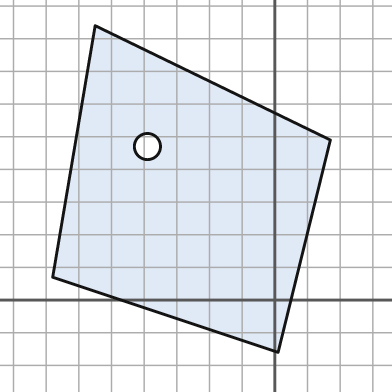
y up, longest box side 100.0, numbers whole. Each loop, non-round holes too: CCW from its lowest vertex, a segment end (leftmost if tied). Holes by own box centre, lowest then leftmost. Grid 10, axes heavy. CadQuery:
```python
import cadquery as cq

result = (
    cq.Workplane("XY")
    .moveTo(1.0, -16.0)
    .lineTo(17.0, 49.0)
    .lineTo(-55.0, 84.0)
    .lineTo(-68.0, 7.0)
    .close()
    .moveTo(-39.0, 47.0)
    .circle(4.0)
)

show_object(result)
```